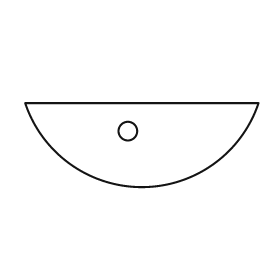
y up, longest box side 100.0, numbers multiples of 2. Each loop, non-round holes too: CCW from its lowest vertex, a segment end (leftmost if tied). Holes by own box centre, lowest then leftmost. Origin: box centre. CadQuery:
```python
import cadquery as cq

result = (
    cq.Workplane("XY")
    .moveTo(-50.0, 18.0)
    .threePointArc((0.0, -18.0), (50.0, 18.0))
    .close()
    .moveTo(-6.0, 6.0)
    .circle(4.0)
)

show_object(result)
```